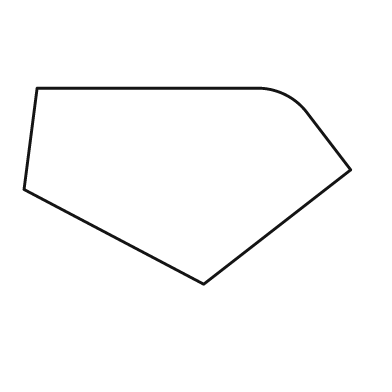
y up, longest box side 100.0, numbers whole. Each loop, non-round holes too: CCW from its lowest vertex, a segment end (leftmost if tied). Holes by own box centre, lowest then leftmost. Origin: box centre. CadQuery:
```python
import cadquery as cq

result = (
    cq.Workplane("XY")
    .moveTo(5.0, -30.0)
    .lineTo(50.0, 5.0)
    .lineTo(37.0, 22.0)
    .threePointArc((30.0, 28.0), (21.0, 30.0))
    .lineTo(-46.0, 30.0)
    .lineTo(-50.0, -1.0)
    .close()
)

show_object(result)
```